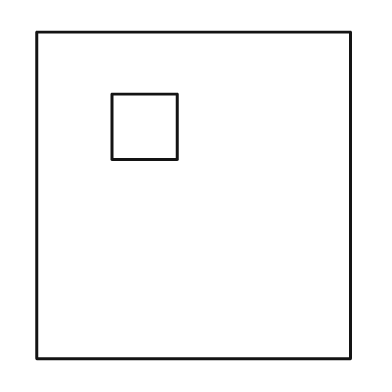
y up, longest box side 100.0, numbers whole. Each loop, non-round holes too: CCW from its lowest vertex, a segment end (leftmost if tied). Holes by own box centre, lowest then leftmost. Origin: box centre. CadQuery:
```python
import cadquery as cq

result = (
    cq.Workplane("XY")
    .moveTo(-48.0, -50.0)
    .lineTo(48.0, -50.0)
    .lineTo(48.0, 50.0)
    .lineTo(-48.0, 50.0)
    .close()
    .moveTo(-25.0, 11.0)
    .lineTo(-5.0, 11.0)
    .lineTo(-5.0, 31.0)
    .lineTo(-25.0, 31.0)
    .close()
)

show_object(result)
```